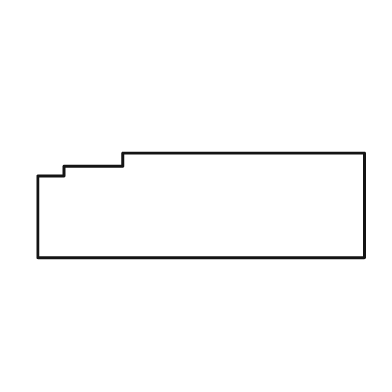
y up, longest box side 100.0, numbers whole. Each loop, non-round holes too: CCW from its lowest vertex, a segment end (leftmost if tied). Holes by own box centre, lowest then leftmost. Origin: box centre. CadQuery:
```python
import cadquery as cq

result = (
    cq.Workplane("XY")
    .moveTo(-50.0, -16.0)
    .lineTo(50.0, -16.0)
    .lineTo(50.0, 16.0)
    .lineTo(-24.0, 16.0)
    .lineTo(-24.0, 12.0)
    .lineTo(-42.0, 12.0)
    .lineTo(-42.0, 9.0)
    .lineTo(-50.0, 9.0)
    .close()
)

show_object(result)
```